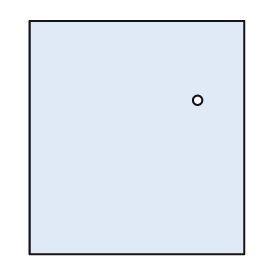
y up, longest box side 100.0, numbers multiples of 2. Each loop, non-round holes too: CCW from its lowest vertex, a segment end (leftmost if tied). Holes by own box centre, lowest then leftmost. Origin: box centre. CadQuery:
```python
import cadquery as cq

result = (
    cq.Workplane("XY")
    .moveTo(-46.0, -50.0)
    .lineTo(46.0, -50.0)
    .lineTo(46.0, 50.0)
    .lineTo(-46.0, 50.0)
    .close()
    .moveTo(26.0, 16.0)
    .circle(2.0)
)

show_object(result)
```